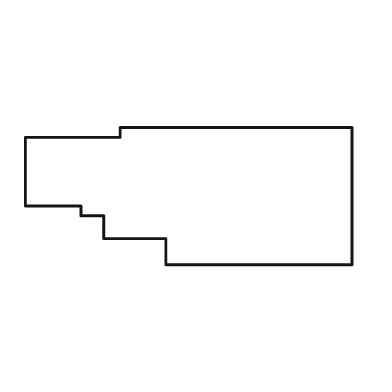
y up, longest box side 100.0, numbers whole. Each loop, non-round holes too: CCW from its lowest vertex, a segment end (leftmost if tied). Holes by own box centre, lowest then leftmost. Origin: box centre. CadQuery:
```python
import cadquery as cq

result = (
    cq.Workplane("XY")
    .moveTo(-7.0, -21.0)
    .lineTo(50.0, -21.0)
    .lineTo(50.0, 21.0)
    .lineTo(-21.0, 21.0)
    .lineTo(-21.0, 18.0)
    .lineTo(-50.0, 18.0)
    .lineTo(-50.0, -3.0)
    .lineTo(-33.0, -3.0)
    .lineTo(-33.0, -6.0)
    .lineTo(-26.0, -6.0)
    .lineTo(-26.0, -13.0)
    .lineTo(-7.0, -13.0)
    .close()
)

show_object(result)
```